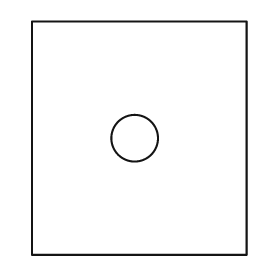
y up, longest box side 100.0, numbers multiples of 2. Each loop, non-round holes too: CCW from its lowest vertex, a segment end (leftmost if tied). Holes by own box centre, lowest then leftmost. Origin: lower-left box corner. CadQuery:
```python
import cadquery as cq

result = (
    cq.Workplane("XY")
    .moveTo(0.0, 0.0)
    .lineTo(92.0, 0.0)
    .lineTo(92.0, 100.0)
    .lineTo(0.0, 100.0)
    .close()
    .moveTo(44.0, 50.0)
    .circle(10.0)
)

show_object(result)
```